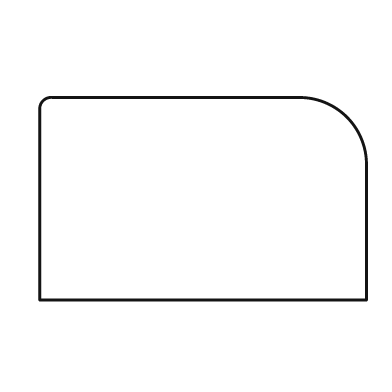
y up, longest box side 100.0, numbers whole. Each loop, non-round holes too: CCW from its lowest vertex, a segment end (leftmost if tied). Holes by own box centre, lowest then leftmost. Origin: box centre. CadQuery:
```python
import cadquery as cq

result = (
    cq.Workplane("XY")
    .moveTo(-50.0, -31.0)
    .lineTo(50.0, -31.0)
    .lineTo(50.0, 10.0)
    .threePointArc((44.0, 25.0), (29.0, 31.0))
    .lineTo(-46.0, 31.0)
    .threePointArc((-49.0, 30.0), (-50.0, 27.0))
    .close()
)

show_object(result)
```